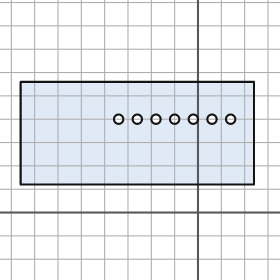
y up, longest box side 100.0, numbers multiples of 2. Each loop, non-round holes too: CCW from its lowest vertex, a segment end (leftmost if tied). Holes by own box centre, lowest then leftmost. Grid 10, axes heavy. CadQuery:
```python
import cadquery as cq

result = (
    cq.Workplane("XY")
    .moveTo(-76.0, 12.0)
    .lineTo(24.0, 12.0)
    .lineTo(24.0, 56.0)
    .lineTo(-76.0, 56.0)
    .close()
    .moveTo(-34.0, 40.0)
    .circle(2.0)
    .moveTo(-26.0, 40.0)
    .circle(2.0)
    .moveTo(-18.0, 40.0)
    .circle(2.0)
    .moveTo(-10.0, 40.0)
    .circle(2.0)
    .moveTo(-2.0, 40.0)
    .circle(2.0)
    .moveTo(6.0, 40.0)
    .circle(2.0)
    .moveTo(14.0, 40.0)
    .circle(2.0)
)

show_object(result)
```